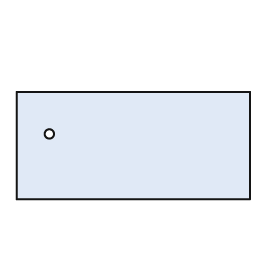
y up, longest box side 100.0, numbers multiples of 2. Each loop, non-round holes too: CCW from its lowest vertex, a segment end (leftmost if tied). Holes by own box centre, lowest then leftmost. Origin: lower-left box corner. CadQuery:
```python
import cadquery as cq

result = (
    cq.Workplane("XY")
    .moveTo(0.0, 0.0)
    .lineTo(100.0, 0.0)
    .lineTo(100.0, 46.0)
    .lineTo(0.0, 46.0)
    .close()
    .moveTo(14.0, 28.0)
    .circle(2.0)
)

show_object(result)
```